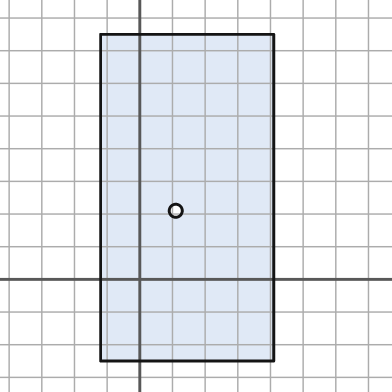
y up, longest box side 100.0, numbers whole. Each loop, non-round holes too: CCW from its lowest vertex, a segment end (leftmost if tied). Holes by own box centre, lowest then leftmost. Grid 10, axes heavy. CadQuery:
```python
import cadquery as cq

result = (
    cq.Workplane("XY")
    .moveTo(-12.0, -25.0)
    .lineTo(41.0, -25.0)
    .lineTo(41.0, 75.0)
    .lineTo(-12.0, 75.0)
    .close()
    .moveTo(11.0, 21.0)
    .circle(2.0)
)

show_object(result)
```